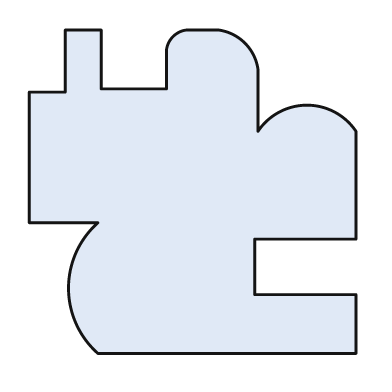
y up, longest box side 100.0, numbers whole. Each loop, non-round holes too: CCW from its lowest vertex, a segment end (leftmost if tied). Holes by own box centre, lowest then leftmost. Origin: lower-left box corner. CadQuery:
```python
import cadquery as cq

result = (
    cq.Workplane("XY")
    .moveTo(21.0, 0.0)
    .lineTo(100.0, 0.0)
    .lineTo(100.0, 18.0)
    .lineTo(69.0, 18.0)
    .lineTo(69.0, 35.0)
    .lineTo(100.0, 35.0)
    .lineTo(100.0, 68.0)
    .threePointArc((85.0, 76.0), (70.0, 68.0))
    .lineTo(70.0, 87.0)
    .threePointArc((66.0, 95.0), (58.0, 99.0))
    .lineTo(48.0, 99.0)
    .threePointArc((44.0, 97.0), (42.0, 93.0))
    .lineTo(42.0, 81.0)
    .lineTo(22.0, 81.0)
    .lineTo(22.0, 99.0)
    .lineTo(11.0, 99.0)
    .lineTo(11.0, 80.0)
    .lineTo(0.0, 80.0)
    .lineTo(0.0, 40.0)
    .lineTo(21.0, 40.0)
    .threePointArc((12.0, 20.0), (21.0, 0.0))
    .close()
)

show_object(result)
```